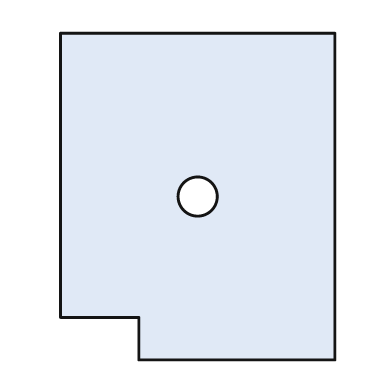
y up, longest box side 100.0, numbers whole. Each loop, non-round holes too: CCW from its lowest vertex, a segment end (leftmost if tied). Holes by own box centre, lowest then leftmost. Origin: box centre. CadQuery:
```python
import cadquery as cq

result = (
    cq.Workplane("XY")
    .moveTo(-18.0, -50.0)
    .lineTo(42.0, -50.0)
    .lineTo(42.0, 50.0)
    .lineTo(-42.0, 50.0)
    .lineTo(-42.0, -37.0)
    .lineTo(-18.0, -37.0)
    .close()
    .moveTo(0.0, 0.0)
    .circle(6.0)
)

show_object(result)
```